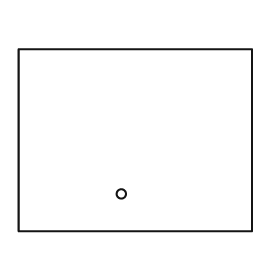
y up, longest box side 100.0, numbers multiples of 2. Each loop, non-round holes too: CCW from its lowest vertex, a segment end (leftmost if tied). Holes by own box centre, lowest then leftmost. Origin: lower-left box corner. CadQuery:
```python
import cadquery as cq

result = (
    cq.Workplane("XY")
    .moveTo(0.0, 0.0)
    .lineTo(100.0, 0.0)
    .lineTo(100.0, 78.0)
    .lineTo(0.0, 78.0)
    .close()
    .moveTo(44.0, 16.0)
    .circle(2.0)
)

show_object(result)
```